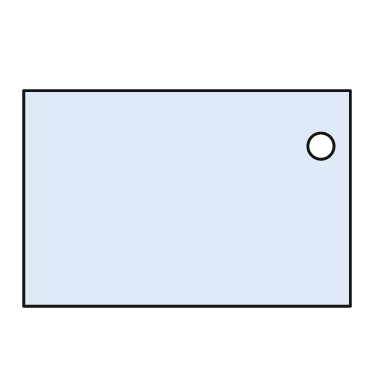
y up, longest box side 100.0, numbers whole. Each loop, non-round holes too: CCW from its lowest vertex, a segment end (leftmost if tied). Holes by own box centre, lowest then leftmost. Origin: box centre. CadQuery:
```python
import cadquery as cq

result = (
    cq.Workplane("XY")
    .moveTo(-50.0, -33.0)
    .lineTo(50.0, -33.0)
    .lineTo(50.0, 33.0)
    .lineTo(-50.0, 33.0)
    .close()
    .moveTo(41.0, 16.0)
    .circle(4.0)
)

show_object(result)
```